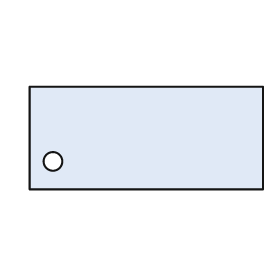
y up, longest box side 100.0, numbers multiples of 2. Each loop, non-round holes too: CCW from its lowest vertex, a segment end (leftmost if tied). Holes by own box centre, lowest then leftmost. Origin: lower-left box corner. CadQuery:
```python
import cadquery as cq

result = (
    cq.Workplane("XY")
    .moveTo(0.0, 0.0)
    .lineTo(100.0, 0.0)
    .lineTo(100.0, 44.0)
    .lineTo(0.0, 44.0)
    .close()
    .moveTo(10.0, 12.0)
    .circle(4.0)
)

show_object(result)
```